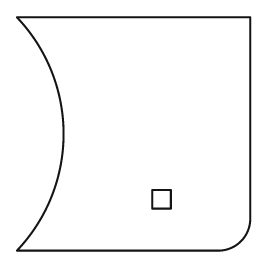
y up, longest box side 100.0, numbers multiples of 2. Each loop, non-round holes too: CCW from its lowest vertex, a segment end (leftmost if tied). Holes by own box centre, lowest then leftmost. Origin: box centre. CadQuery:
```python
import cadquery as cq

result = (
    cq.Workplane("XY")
    .moveTo(-50.0, -50.0)
    .lineTo(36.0, -50.0)
    .threePointArc((46.0, -46.0), (50.0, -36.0))
    .lineTo(50.0, 50.0)
    .lineTo(-50.0, 50.0)
    .threePointArc((-30.0, 0.0), (-50.0, -50.0))
    .close()
    .moveTo(8.0, -32.0)
    .lineTo(16.0, -32.0)
    .lineTo(16.0, -24.0)
    .lineTo(8.0, -24.0)
    .close()
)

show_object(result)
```